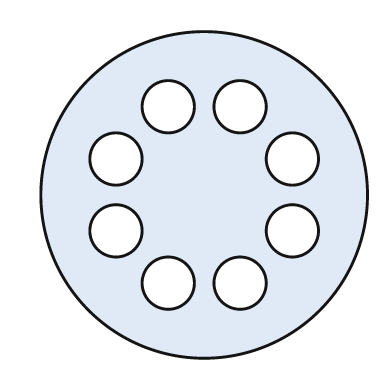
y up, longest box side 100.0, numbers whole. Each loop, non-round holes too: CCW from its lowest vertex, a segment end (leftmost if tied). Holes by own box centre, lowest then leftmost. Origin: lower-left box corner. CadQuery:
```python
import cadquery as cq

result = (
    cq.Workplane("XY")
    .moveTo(50.0, 50.0)
    .circle(50.0)
    .moveTo(39.0, 23.0)
    .circle(8.0)
    .moveTo(61.0, 23.0)
    .circle(8.0)
    .moveTo(23.0, 39.0)
    .circle(8.0)
    .moveTo(77.0, 39.0)
    .circle(8.0)
    .moveTo(23.0, 61.0)
    .circle(8.0)
    .moveTo(77.0, 61.0)
    .circle(8.0)
    .moveTo(39.0, 77.0)
    .circle(8.0)
    .moveTo(61.0, 77.0)
    .circle(8.0)
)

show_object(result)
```